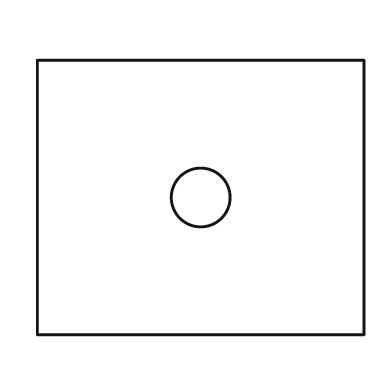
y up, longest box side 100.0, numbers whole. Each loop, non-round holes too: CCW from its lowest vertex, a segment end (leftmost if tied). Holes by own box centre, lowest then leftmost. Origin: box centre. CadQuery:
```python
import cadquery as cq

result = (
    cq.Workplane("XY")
    .moveTo(-50.0, -42.0)
    .lineTo(50.0, -42.0)
    .lineTo(50.0, 42.0)
    .lineTo(-50.0, 42.0)
    .close()
    .moveTo(0.0, 0.0)
    .circle(9.0)
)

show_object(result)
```